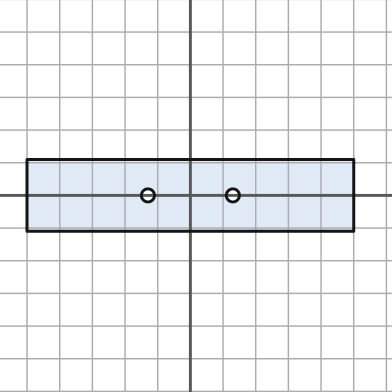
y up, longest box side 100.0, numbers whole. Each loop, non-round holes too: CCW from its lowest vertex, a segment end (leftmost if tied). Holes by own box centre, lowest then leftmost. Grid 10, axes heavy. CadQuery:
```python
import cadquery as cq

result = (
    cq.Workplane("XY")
    .moveTo(-50.0, -11.0)
    .lineTo(50.0, -11.0)
    .lineTo(50.0, 11.0)
    .lineTo(-50.0, 11.0)
    .close()
    .moveTo(-13.0, 0.0)
    .circle(2.0)
    .moveTo(13.0, 0.0)
    .circle(2.0)
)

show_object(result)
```